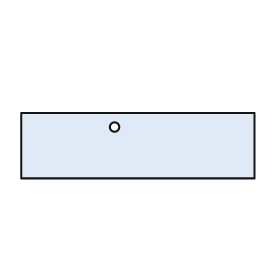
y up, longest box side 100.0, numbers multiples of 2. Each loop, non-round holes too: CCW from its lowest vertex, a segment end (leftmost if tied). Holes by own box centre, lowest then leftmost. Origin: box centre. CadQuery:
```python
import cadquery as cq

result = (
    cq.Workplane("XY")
    .moveTo(-50.0, -14.0)
    .lineTo(50.0, -14.0)
    .lineTo(50.0, 14.0)
    .lineTo(-50.0, 14.0)
    .close()
    .moveTo(-10.0, 8.0)
    .circle(2.0)
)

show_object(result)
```